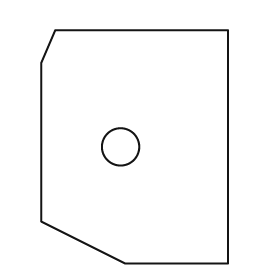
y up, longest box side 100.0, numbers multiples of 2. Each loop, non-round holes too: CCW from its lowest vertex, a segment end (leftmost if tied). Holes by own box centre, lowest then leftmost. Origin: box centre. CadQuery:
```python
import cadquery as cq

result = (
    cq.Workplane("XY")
    .moveTo(-4.0, -50.0)
    .lineTo(40.0, -50.0)
    .lineTo(40.0, 50.0)
    .lineTo(-34.0, 50.0)
    .lineTo(-40.0, 36.0)
    .lineTo(-40.0, -32.0)
    .close()
    .moveTo(-6.0, 0.0)
    .circle(8.0)
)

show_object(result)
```